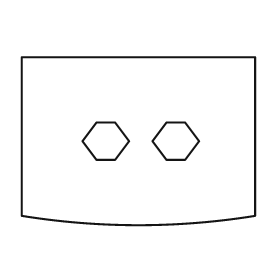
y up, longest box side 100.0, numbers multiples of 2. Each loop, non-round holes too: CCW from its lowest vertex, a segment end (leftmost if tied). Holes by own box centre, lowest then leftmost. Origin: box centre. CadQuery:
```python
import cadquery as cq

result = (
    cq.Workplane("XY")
    .moveTo(-50.0, -32.0)
    .threePointArc((0.0, -36.0), (50.0, -32.0))
    .lineTo(50.0, 36.0)
    .lineTo(-50.0, 36.0)
    .close()
    .moveTo(-18.0, -8.0)
    .lineTo(-10.0, -8.0)
    .lineTo(-4.0, 0.0)
    .lineTo(-10.0, 8.0)
    .lineTo(-18.0, 8.0)
    .lineTo(-24.0, 0.0)
    .close()
    .moveTo(12.0, -8.0)
    .lineTo(20.0, -8.0)
    .lineTo(26.0, 0.0)
    .lineTo(20.0, 8.0)
    .lineTo(12.0, 8.0)
    .lineTo(6.0, 0.0)
    .close()
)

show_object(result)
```